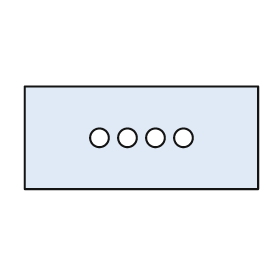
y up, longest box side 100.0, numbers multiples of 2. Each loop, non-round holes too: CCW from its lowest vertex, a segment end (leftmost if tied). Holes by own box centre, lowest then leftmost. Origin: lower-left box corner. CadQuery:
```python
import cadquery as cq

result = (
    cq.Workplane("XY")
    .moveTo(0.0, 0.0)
    .lineTo(100.0, 0.0)
    .lineTo(100.0, 44.0)
    .lineTo(0.0, 44.0)
    .close()
    .moveTo(32.0, 22.0)
    .circle(4.0)
    .moveTo(44.0, 22.0)
    .circle(4.0)
    .moveTo(56.0, 22.0)
    .circle(4.0)
    .moveTo(68.0, 22.0)
    .circle(4.0)
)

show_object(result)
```